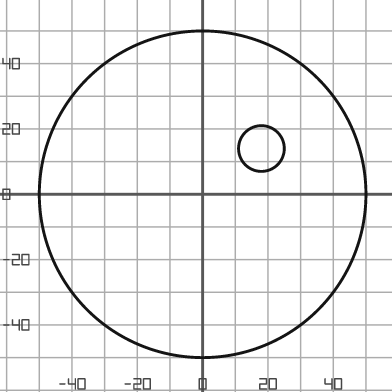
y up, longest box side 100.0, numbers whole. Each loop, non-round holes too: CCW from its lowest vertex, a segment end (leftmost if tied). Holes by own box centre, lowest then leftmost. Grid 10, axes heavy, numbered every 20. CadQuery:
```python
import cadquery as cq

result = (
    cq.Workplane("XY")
    .moveTo(0.0, 0.0)
    .circle(50.0)
    .moveTo(18.0, 14.0)
    .circle(7.0)
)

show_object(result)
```